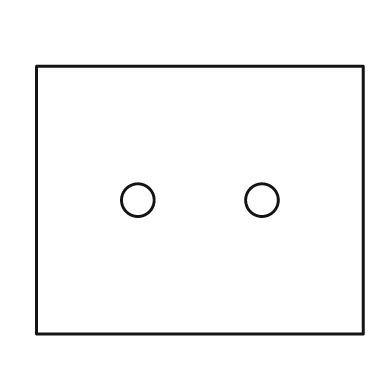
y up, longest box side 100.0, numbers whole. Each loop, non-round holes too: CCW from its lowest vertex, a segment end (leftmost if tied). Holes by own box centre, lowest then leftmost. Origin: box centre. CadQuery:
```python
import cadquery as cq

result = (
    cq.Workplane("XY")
    .moveTo(-50.0, -41.0)
    .lineTo(50.0, -41.0)
    .lineTo(50.0, 41.0)
    .lineTo(-50.0, 41.0)
    .close()
    .moveTo(-19.0, 0.0)
    .circle(5.0)
    .moveTo(19.0, 0.0)
    .circle(5.0)
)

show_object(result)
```